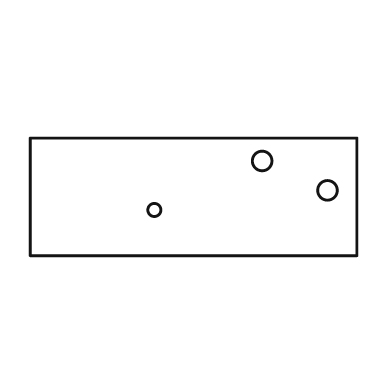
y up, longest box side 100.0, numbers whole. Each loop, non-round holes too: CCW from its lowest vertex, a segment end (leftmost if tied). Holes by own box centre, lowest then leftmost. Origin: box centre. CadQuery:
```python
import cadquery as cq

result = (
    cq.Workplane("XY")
    .moveTo(-50.0, -18.0)
    .lineTo(50.0, -18.0)
    .lineTo(50.0, 18.0)
    .lineTo(-50.0, 18.0)
    .close()
    .moveTo(-12.0, -4.0)
    .circle(2.0)
    .moveTo(41.0, 2.0)
    .circle(3.0)
    .moveTo(21.0, 11.0)
    .circle(3.0)
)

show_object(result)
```